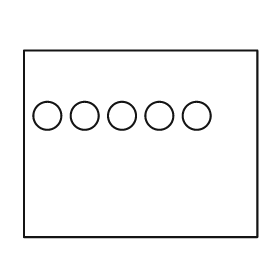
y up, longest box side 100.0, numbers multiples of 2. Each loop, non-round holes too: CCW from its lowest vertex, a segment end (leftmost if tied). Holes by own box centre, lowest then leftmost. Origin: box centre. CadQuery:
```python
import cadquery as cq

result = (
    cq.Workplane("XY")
    .moveTo(-50.0, -40.0)
    .lineTo(50.0, -40.0)
    .lineTo(50.0, 40.0)
    .lineTo(-50.0, 40.0)
    .close()
    .moveTo(-40.0, 12.0)
    .circle(6.0)
    .moveTo(-24.0, 12.0)
    .circle(6.0)
    .moveTo(-8.0, 12.0)
    .circle(6.0)
    .moveTo(8.0, 12.0)
    .circle(6.0)
    .moveTo(24.0, 12.0)
    .circle(6.0)
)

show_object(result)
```